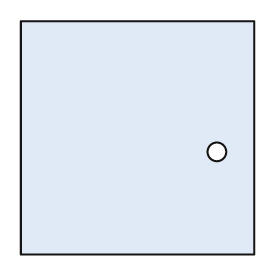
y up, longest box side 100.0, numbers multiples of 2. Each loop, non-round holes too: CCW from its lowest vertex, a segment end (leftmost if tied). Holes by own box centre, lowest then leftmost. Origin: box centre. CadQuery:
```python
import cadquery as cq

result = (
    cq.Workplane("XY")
    .moveTo(-50.0, -50.0)
    .lineTo(50.0, -50.0)
    .lineTo(50.0, 50.0)
    .lineTo(-50.0, 50.0)
    .close()
    .moveTo(34.0, -6.0)
    .circle(4.0)
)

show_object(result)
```